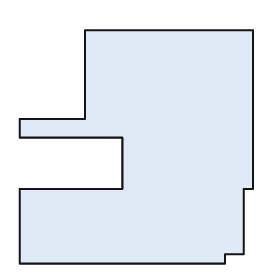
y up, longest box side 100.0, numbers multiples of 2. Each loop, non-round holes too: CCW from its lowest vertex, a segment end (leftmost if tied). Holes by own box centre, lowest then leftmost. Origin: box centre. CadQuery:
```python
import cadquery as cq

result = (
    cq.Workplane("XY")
    .moveTo(-50.0, -50.0)
    .lineTo(38.0, -50.0)
    .lineTo(38.0, -46.0)
    .lineTo(46.0, -46.0)
    .lineTo(46.0, -18.0)
    .lineTo(50.0, -18.0)
    .lineTo(50.0, 50.0)
    .lineTo(-22.0, 50.0)
    .lineTo(-22.0, 12.0)
    .lineTo(-50.0, 12.0)
    .lineTo(-50.0, 4.0)
    .lineTo(-6.0, 4.0)
    .lineTo(-6.0, -18.0)
    .lineTo(-50.0, -18.0)
    .close()
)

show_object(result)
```